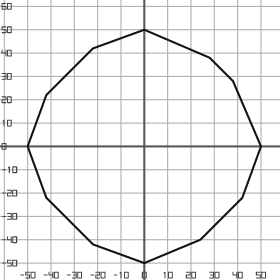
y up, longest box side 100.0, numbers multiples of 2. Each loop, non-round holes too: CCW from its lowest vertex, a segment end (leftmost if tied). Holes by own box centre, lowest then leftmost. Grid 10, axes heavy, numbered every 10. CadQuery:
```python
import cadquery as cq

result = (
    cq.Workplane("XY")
    .moveTo(0.0, -50.0)
    .lineTo(24.0, -40.0)
    .lineTo(42.0, -22.0)
    .lineTo(50.0, 0.0)
    .lineTo(38.0, 28.0)
    .lineTo(28.0, 38.0)
    .lineTo(0.0, 50.0)
    .lineTo(-22.0, 42.0)
    .lineTo(-42.0, 22.0)
    .lineTo(-50.0, 0.0)
    .lineTo(-42.0, -22.0)
    .lineTo(-22.0, -42.0)
    .close()
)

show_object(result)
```